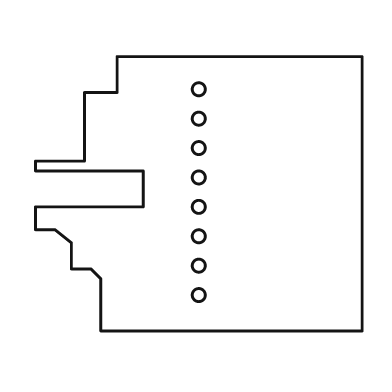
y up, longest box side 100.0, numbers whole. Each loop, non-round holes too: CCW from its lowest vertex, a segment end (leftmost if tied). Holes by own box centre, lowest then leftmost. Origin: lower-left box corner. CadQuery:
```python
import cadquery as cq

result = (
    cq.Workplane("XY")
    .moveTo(20.0, 0.0)
    .lineTo(100.0, 0.0)
    .lineTo(100.0, 84.0)
    .lineTo(25.0, 84.0)
    .lineTo(25.0, 73.0)
    .lineTo(15.0, 73.0)
    .lineTo(15.0, 52.0)
    .lineTo(0.0, 52.0)
    .lineTo(0.0, 49.0)
    .lineTo(33.0, 49.0)
    .lineTo(33.0, 38.0)
    .lineTo(0.0, 38.0)
    .lineTo(0.0, 31.0)
    .lineTo(6.0, 31.0)
    .lineTo(11.0, 27.0)
    .lineTo(11.0, 19.0)
    .lineTo(17.0, 19.0)
    .lineTo(20.0, 16.0)
    .close()
    .moveTo(50.0, 11.0)
    .circle(2.0)
    .moveTo(50.0, 20.0)
    .circle(2.0)
    .moveTo(50.0, 29.0)
    .circle(2.0)
    .moveTo(50.0, 38.0)
    .circle(2.0)
    .moveTo(50.0, 47.0)
    .circle(2.0)
    .moveTo(50.0, 56.0)
    .circle(2.0)
    .moveTo(50.0, 65.0)
    .circle(2.0)
    .moveTo(50.0, 74.0)
    .circle(2.0)
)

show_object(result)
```